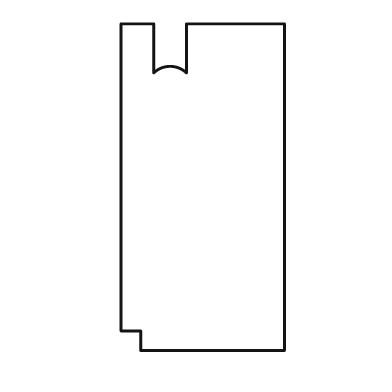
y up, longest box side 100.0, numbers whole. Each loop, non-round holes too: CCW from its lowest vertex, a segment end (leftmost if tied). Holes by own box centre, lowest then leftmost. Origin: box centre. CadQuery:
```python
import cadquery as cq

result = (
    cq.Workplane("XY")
    .moveTo(-19.0, -50.0)
    .lineTo(25.0, -50.0)
    .lineTo(25.0, 50.0)
    .lineTo(-5.0, 50.0)
    .lineTo(-5.0, 35.0)
    .threePointArc((-10.0, 37.0), (-15.0, 35.0))
    .lineTo(-15.0, 50.0)
    .lineTo(-25.0, 50.0)
    .lineTo(-25.0, -44.0)
    .lineTo(-19.0, -44.0)
    .close()
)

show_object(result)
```